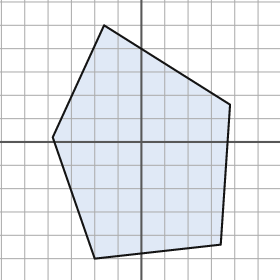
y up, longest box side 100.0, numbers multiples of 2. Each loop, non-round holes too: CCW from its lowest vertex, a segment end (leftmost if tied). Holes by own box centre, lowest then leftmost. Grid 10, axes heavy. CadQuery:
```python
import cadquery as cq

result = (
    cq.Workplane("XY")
    .moveTo(-20.0, -50.0)
    .lineTo(34.0, -44.0)
    .lineTo(38.0, 16.0)
    .lineTo(-16.0, 50.0)
    .lineTo(-38.0, 2.0)
    .close()
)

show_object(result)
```